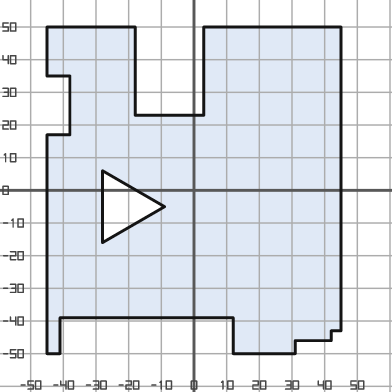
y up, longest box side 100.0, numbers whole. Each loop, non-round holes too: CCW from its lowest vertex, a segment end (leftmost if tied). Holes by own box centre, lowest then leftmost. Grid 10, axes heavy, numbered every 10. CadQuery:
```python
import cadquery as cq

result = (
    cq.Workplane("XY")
    .moveTo(-45.0, -50.0)
    .lineTo(-41.0, -50.0)
    .lineTo(-41.0, -39.0)
    .lineTo(12.0, -39.0)
    .lineTo(12.0, -50.0)
    .lineTo(31.0, -50.0)
    .lineTo(31.0, -46.0)
    .lineTo(42.0, -46.0)
    .lineTo(42.0, -43.0)
    .lineTo(45.0, -43.0)
    .lineTo(45.0, 50.0)
    .lineTo(3.0, 50.0)
    .lineTo(3.0, 23.0)
    .lineTo(-18.0, 23.0)
    .lineTo(-18.0, 50.0)
    .lineTo(-45.0, 50.0)
    .lineTo(-45.0, 35.0)
    .lineTo(-38.0, 35.0)
    .lineTo(-38.0, 17.0)
    .lineTo(-45.0, 17.0)
    .close()
    .moveTo(-28.0, -16.0)
    .lineTo(-9.0, -5.0)
    .lineTo(-28.0, 6.0)
    .close()
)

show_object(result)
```